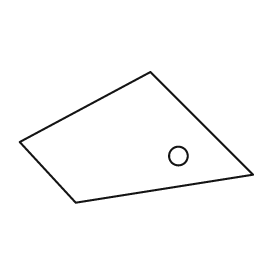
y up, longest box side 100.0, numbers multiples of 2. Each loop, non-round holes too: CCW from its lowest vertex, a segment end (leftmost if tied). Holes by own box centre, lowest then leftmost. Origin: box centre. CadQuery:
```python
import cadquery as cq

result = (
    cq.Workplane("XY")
    .moveTo(-26.0, -28.0)
    .lineTo(50.0, -16.0)
    .lineTo(6.0, 28.0)
    .lineTo(-50.0, -2.0)
    .close()
    .moveTo(18.0, -8.0)
    .circle(4.0)
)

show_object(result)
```